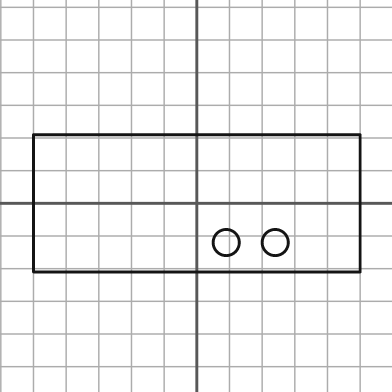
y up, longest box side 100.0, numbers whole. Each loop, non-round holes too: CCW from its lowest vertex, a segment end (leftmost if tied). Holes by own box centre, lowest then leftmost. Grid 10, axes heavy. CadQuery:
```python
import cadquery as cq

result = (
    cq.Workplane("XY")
    .moveTo(-50.0, -21.0)
    .lineTo(50.0, -21.0)
    .lineTo(50.0, 21.0)
    .lineTo(-50.0, 21.0)
    .close()
    .moveTo(9.0, -12.0)
    .circle(4.0)
    .moveTo(24.0, -12.0)
    .circle(4.0)
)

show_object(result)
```